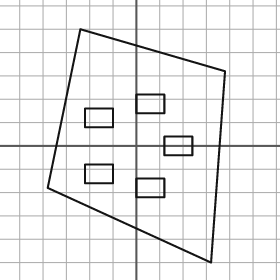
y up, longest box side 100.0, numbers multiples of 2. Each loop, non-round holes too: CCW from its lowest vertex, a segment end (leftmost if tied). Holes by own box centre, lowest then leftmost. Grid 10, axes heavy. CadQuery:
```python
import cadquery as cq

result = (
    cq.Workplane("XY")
    .moveTo(32.0, -50.0)
    .lineTo(38.0, 32.0)
    .lineTo(-24.0, 50.0)
    .lineTo(-38.0, -18.0)
    .close()
    .moveTo(0.0, -22.0)
    .lineTo(12.0, -22.0)
    .lineTo(12.0, -14.0)
    .lineTo(0.0, -14.0)
    .close()
    .moveTo(-22.0, -16.0)
    .lineTo(-10.0, -16.0)
    .lineTo(-10.0, -8.0)
    .lineTo(-22.0, -8.0)
    .close()
    .moveTo(12.0, -4.0)
    .lineTo(24.0, -4.0)
    .lineTo(24.0, 4.0)
    .lineTo(12.0, 4.0)
    .close()
    .moveTo(-22.0, 8.0)
    .lineTo(-10.0, 8.0)
    .lineTo(-10.0, 16.0)
    .lineTo(-22.0, 16.0)
    .close()
    .moveTo(0.0, 14.0)
    .lineTo(12.0, 14.0)
    .lineTo(12.0, 22.0)
    .lineTo(0.0, 22.0)
    .close()
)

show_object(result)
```